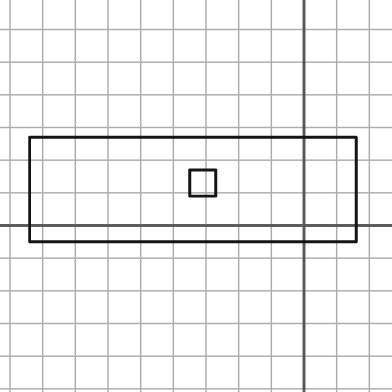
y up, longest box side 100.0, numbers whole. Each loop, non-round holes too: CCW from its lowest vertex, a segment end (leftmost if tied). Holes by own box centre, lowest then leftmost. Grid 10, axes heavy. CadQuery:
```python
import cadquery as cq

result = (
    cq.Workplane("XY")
    .moveTo(-84.0, -5.0)
    .lineTo(16.0, -5.0)
    .lineTo(16.0, 27.0)
    .lineTo(-84.0, 27.0)
    .close()
    .moveTo(-35.0, 9.0)
    .lineTo(-27.0, 9.0)
    .lineTo(-27.0, 17.0)
    .lineTo(-35.0, 17.0)
    .close()
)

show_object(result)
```